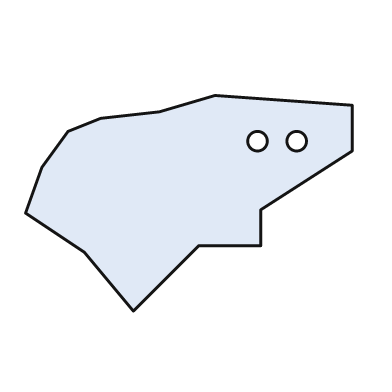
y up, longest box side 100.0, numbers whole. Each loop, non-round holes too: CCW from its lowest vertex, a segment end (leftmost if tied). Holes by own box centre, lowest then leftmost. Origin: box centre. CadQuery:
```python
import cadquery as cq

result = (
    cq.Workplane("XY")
    .moveTo(-17.0, -33.0)
    .lineTo(3.0, -13.0)
    .lineTo(22.0, -13.0)
    .lineTo(22.0, -2.0)
    .lineTo(50.0, 16.0)
    .lineTo(50.0, 30.0)
    .lineTo(8.0, 33.0)
    .lineTo(-9.0, 28.0)
    .lineTo(-27.0, 26.0)
    .lineTo(-37.0, 22.0)
    .lineTo(-45.0, 11.0)
    .lineTo(-50.0, -3.0)
    .lineTo(-32.0, -15.0)
    .close()
    .moveTo(21.0, 19.0)
    .circle(3.0)
    .moveTo(33.0, 19.0)
    .circle(3.0)
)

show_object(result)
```